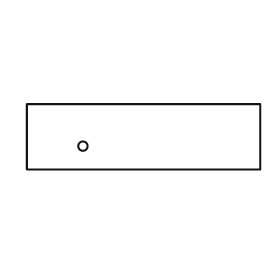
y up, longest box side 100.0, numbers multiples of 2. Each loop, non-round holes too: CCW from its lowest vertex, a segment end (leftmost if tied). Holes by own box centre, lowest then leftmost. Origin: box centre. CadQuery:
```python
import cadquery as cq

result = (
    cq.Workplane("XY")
    .moveTo(-50.0, -14.0)
    .lineTo(50.0, -14.0)
    .lineTo(50.0, 14.0)
    .lineTo(-50.0, 14.0)
    .close()
    .moveTo(-26.0, -4.0)
    .circle(2.0)
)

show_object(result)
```